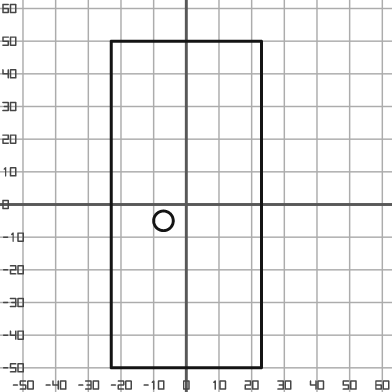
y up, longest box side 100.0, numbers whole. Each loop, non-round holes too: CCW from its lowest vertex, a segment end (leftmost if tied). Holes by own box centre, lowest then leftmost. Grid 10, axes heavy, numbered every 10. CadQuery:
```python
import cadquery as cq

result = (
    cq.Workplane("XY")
    .moveTo(-23.0, -50.0)
    .lineTo(23.0, -50.0)
    .lineTo(23.0, 50.0)
    .lineTo(-23.0, 50.0)
    .close()
    .moveTo(-7.0, -5.0)
    .circle(3.0)
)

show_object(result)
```